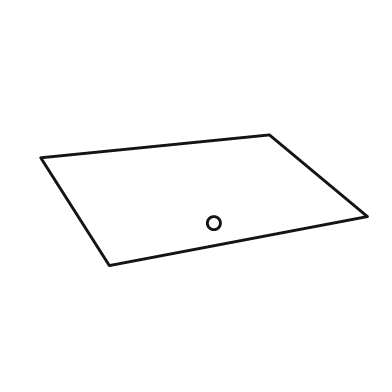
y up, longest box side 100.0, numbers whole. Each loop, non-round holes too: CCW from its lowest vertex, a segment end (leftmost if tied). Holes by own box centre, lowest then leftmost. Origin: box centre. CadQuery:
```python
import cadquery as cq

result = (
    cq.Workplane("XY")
    .moveTo(-29.0, -20.0)
    .lineTo(50.0, -5.0)
    .lineTo(20.0, 20.0)
    .lineTo(-50.0, 13.0)
    .close()
    .moveTo(3.0, -7.0)
    .circle(2.0)
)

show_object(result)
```